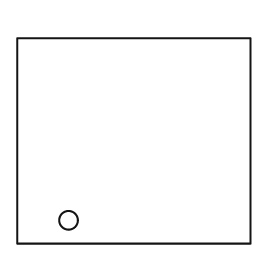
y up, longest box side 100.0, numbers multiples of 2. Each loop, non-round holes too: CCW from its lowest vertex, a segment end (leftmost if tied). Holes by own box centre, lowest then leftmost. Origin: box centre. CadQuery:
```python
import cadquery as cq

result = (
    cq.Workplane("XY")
    .moveTo(-50.0, -44.0)
    .lineTo(50.0, -44.0)
    .lineTo(50.0, 44.0)
    .lineTo(-50.0, 44.0)
    .close()
    .moveTo(-28.0, -34.0)
    .circle(4.0)
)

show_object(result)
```